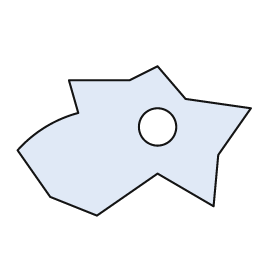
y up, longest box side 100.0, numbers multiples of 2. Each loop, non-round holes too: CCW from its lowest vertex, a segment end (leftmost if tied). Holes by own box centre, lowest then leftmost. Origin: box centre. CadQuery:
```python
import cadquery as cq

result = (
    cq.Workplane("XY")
    .moveTo(-16.0, -32.0)
    .lineTo(10.0, -14.0)
    .lineTo(34.0, -28.0)
    .lineTo(36.0, -6.0)
    .lineTo(50.0, 14.0)
    .lineTo(22.0, 18.0)
    .lineTo(10.0, 32.0)
    .lineTo(-2.0, 26.0)
    .lineTo(-28.0, 26.0)
    .lineTo(-24.0, 12.0)
    .threePointArc((-38.0, 6.0), (-50.0, -4.0))
    .lineTo(-36.0, -24.0)
    .close()
    .moveTo(10.0, 6.0)
    .circle(8.0)
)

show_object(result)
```